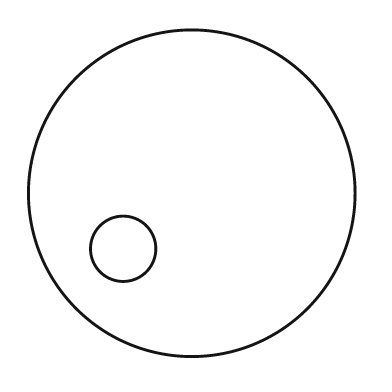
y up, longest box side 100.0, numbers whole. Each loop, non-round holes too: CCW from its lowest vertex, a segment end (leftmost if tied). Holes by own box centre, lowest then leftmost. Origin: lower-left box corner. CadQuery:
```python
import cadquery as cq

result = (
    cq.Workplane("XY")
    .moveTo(50.0, 50.0)
    .circle(50.0)
    .moveTo(29.0, 33.0)
    .circle(10.0)
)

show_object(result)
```